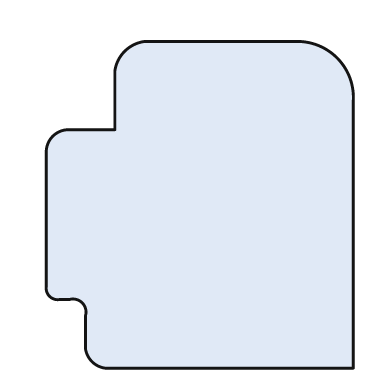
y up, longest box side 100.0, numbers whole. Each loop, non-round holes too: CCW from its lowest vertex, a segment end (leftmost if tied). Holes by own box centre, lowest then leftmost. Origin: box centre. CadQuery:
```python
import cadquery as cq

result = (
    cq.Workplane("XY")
    .moveTo(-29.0, -50.0)
    .lineTo(47.0, -50.0)
    .lineTo(47.0, 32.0)
    .threePointArc((42.0, 45.0), (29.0, 50.0))
    .lineTo(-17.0, 50.0)
    .threePointArc((-23.0, 47.0), (-26.0, 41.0))
    .lineTo(-26.0, 23.0)
    .lineTo(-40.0, 23.0)
    .threePointArc((-45.0, 21.0), (-47.0, 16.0))
    .lineTo(-47.0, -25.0)
    .threePointArc((-46.0, -28.0), (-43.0, -29.0))
    .lineTo(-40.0, -29.0)
    .threePointArc((-36.0, -30.0), (-35.0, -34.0))
    .lineTo(-35.0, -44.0)
    .threePointArc((-33.0, -48.0), (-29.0, -50.0))
    .close()
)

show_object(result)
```